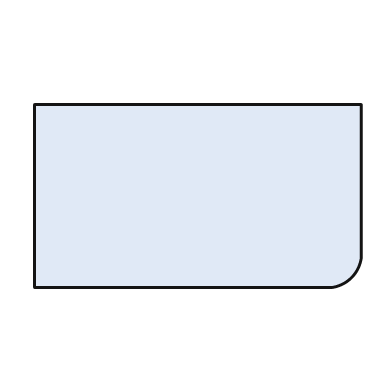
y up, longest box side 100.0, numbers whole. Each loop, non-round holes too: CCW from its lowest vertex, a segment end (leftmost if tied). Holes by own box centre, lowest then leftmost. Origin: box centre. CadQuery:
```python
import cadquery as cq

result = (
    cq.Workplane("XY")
    .moveTo(-50.0, -28.0)
    .lineTo(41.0, -28.0)
    .threePointArc((47.0, -25.0), (50.0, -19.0))
    .lineTo(50.0, 28.0)
    .lineTo(-50.0, 28.0)
    .close()
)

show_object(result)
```